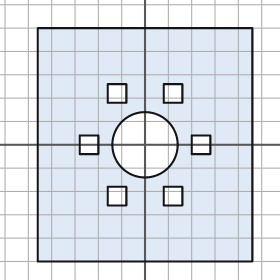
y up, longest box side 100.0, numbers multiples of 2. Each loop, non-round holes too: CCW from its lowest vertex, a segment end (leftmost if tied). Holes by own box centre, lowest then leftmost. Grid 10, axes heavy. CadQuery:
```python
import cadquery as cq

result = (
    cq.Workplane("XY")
    .moveTo(-46.0, -50.0)
    .lineTo(46.0, -50.0)
    .lineTo(46.0, 50.0)
    .lineTo(-46.0, 50.0)
    .close()
    .moveTo(-16.0, -26.0)
    .lineTo(-8.0, -26.0)
    .lineTo(-8.0, -18.0)
    .lineTo(-16.0, -18.0)
    .close()
    .moveTo(8.0, -26.0)
    .lineTo(16.0, -26.0)
    .lineTo(16.0, -18.0)
    .lineTo(8.0, -18.0)
    .close()
    .moveTo(-28.0, -4.0)
    .lineTo(-20.0, -4.0)
    .lineTo(-20.0, 4.0)
    .lineTo(-28.0, 4.0)
    .close()
    .moveTo(0.0, 0.0)
    .circle(14.0)
    .moveTo(20.0, -4.0)
    .lineTo(28.0, -4.0)
    .lineTo(28.0, 4.0)
    .lineTo(20.0, 4.0)
    .close()
    .moveTo(-16.0, 18.0)
    .lineTo(-8.0, 18.0)
    .lineTo(-8.0, 26.0)
    .lineTo(-16.0, 26.0)
    .close()
    .moveTo(8.0, 18.0)
    .lineTo(16.0, 18.0)
    .lineTo(16.0, 26.0)
    .lineTo(8.0, 26.0)
    .close()
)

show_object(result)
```